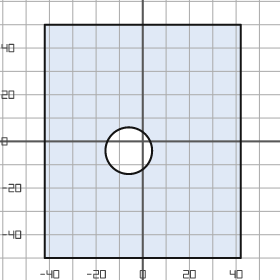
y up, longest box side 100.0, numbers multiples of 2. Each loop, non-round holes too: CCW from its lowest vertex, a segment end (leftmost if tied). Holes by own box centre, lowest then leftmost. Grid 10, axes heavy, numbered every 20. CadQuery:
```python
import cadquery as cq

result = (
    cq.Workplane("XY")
    .moveTo(-42.0, -50.0)
    .lineTo(42.0, -50.0)
    .lineTo(42.0, 50.0)
    .lineTo(-42.0, 50.0)
    .close()
    .moveTo(-6.0, -4.0)
    .circle(10.0)
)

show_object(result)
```